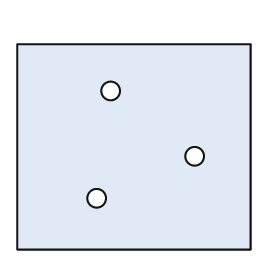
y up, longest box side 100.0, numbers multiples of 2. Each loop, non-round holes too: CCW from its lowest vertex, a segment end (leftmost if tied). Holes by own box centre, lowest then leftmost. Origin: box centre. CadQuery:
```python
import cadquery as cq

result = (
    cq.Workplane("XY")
    .moveTo(-50.0, -44.0)
    .lineTo(50.0, -44.0)
    .lineTo(50.0, 44.0)
    .lineTo(-50.0, 44.0)
    .close()
    .moveTo(-16.0, -22.0)
    .circle(4.0)
    .moveTo(26.0, -4.0)
    .circle(4.0)
    .moveTo(-10.0, 24.0)
    .circle(4.0)
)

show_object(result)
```